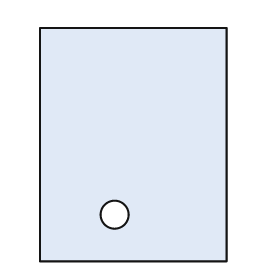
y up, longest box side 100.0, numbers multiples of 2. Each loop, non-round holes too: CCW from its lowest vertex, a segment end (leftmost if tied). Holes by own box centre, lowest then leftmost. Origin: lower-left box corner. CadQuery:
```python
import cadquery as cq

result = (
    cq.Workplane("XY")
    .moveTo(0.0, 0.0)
    .lineTo(80.0, 0.0)
    .lineTo(80.0, 100.0)
    .lineTo(0.0, 100.0)
    .close()
    .moveTo(32.0, 20.0)
    .circle(6.0)
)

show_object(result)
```